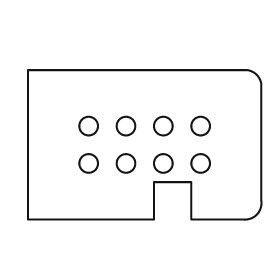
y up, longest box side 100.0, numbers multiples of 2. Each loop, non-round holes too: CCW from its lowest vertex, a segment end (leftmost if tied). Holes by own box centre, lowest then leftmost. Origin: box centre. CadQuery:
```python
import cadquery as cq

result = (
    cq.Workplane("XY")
    .moveTo(-50.0, -32.0)
    .lineTo(4.0, -32.0)
    .lineTo(4.0, -16.0)
    .lineTo(20.0, -16.0)
    .lineTo(20.0, -32.0)
    .lineTo(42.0, -32.0)
    .threePointArc((48.0, -30.0), (50.0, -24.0))
    .lineTo(50.0, 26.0)
    .threePointArc((48.0, 30.0), (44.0, 32.0))
    .lineTo(-50.0, 32.0)
    .close()
    .moveTo(-24.0, -8.0)
    .circle(4.0)
    .moveTo(-8.0, -8.0)
    .circle(4.0)
    .moveTo(8.0, -8.0)
    .circle(4.0)
    .moveTo(24.0, -8.0)
    .circle(4.0)
    .moveTo(-24.0, 8.0)
    .circle(4.0)
    .moveTo(-8.0, 8.0)
    .circle(4.0)
    .moveTo(8.0, 8.0)
    .circle(4.0)
    .moveTo(24.0, 8.0)
    .circle(4.0)
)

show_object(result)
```